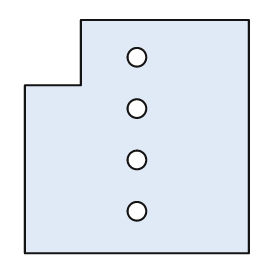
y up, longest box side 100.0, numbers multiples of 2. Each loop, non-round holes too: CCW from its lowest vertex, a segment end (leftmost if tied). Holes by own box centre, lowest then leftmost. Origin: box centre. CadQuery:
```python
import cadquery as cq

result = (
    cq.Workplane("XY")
    .moveTo(-48.0, -50.0)
    .lineTo(48.0, -50.0)
    .lineTo(48.0, 50.0)
    .lineTo(-24.0, 50.0)
    .lineTo(-24.0, 22.0)
    .lineTo(-48.0, 22.0)
    .close()
    .moveTo(0.0, -32.0)
    .circle(4.0)
    .moveTo(0.0, -10.0)
    .circle(4.0)
    .moveTo(0.0, 12.0)
    .circle(4.0)
    .moveTo(0.0, 34.0)
    .circle(4.0)
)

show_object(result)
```